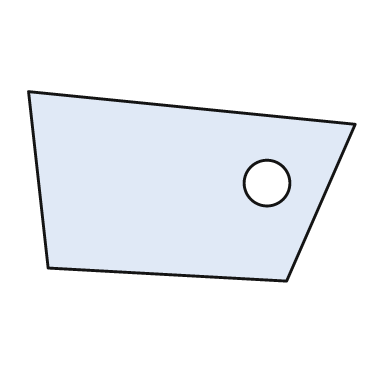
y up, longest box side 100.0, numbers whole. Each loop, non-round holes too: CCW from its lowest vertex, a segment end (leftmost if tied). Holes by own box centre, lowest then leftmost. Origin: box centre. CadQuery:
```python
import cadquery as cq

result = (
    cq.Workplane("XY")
    .moveTo(29.0, -29.0)
    .lineTo(50.0, 19.0)
    .lineTo(-50.0, 29.0)
    .lineTo(-44.0, -25.0)
    .close()
    .moveTo(23.0, 1.0)
    .circle(7.0)
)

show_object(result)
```